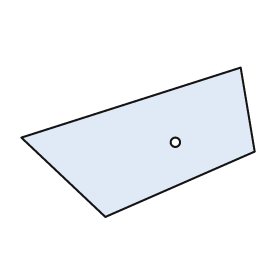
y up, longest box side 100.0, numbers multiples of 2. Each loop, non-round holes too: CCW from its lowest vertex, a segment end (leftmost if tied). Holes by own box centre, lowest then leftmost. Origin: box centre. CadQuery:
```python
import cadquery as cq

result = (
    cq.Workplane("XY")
    .moveTo(-14.0, -32.0)
    .lineTo(50.0, -4.0)
    .lineTo(44.0, 32.0)
    .lineTo(-50.0, 2.0)
    .close()
    .moveTo(16.0, 0.0)
    .circle(2.0)
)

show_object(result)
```